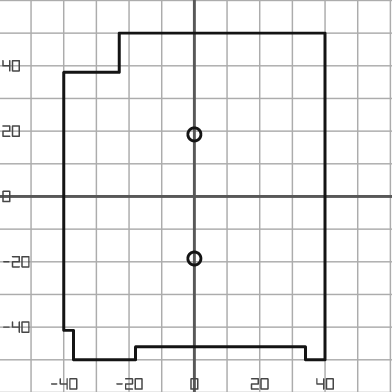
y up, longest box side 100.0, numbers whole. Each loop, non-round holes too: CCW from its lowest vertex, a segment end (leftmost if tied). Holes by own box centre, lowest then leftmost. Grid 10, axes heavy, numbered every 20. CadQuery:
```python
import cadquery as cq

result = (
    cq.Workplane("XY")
    .moveTo(-37.0, -50.0)
    .lineTo(-18.0, -50.0)
    .lineTo(-18.0, -46.0)
    .lineTo(34.0, -46.0)
    .lineTo(34.0, -50.0)
    .lineTo(40.0, -50.0)
    .lineTo(40.0, 50.0)
    .lineTo(-23.0, 50.0)
    .lineTo(-23.0, 38.0)
    .lineTo(-40.0, 38.0)
    .lineTo(-40.0, -41.0)
    .lineTo(-37.0, -41.0)
    .close()
    .moveTo(0.0, -19.0)
    .circle(2.0)
    .moveTo(0.0, 19.0)
    .circle(2.0)
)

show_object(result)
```